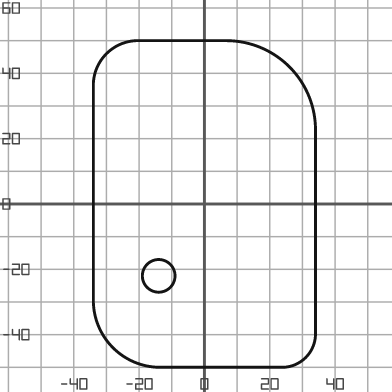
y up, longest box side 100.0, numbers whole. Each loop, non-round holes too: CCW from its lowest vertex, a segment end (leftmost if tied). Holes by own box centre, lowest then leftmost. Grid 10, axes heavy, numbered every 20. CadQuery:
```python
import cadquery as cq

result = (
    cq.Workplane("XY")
    .moveTo(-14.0, -50.0)
    .lineTo(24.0, -50.0)
    .threePointArc((31.0, -47.0), (34.0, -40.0))
    .lineTo(34.0, 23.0)
    .threePointArc((26.0, 42.0), (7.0, 50.0))
    .lineTo(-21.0, 50.0)
    .threePointArc((-30.0, 46.0), (-34.0, 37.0))
    .lineTo(-34.0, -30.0)
    .threePointArc((-28.0, -44.0), (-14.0, -50.0))
    .close()
    .moveTo(-14.0, -22.0)
    .circle(5.0)
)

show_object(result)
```